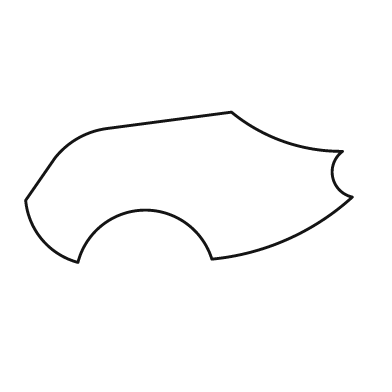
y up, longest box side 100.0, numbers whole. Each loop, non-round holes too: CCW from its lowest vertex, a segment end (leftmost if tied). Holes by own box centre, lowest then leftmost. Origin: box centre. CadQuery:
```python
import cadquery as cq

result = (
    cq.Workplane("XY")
    .moveTo(-34.0, -23.0)
    .threePointArc((-14.0, -7.0), (7.0, -22.0))
    .threePointArc((30.0, -16.0), (50.0, -3.0))
    .threePointArc((44.0, 3.0), (47.0, 11.0))
    .threePointArc((29.0, 14.0), (13.0, 23.0))
    .lineTo(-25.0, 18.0)
    .threePointArc((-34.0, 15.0), (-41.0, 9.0))
    .lineTo(-50.0, -4.0)
    .threePointArc((-45.0, -16.0), (-34.0, -23.0))
    .close()
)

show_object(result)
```